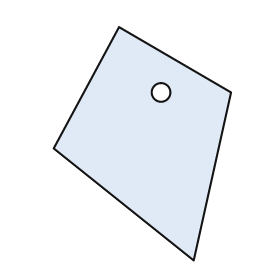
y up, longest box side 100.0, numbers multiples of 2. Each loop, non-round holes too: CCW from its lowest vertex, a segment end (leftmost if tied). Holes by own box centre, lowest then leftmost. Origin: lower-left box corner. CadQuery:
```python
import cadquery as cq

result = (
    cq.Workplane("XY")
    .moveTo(60.0, 0.0)
    .lineTo(76.0, 72.0)
    .lineTo(28.0, 100.0)
    .lineTo(0.0, 48.0)
    .close()
    .moveTo(46.0, 72.0)
    .circle(4.0)
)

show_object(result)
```